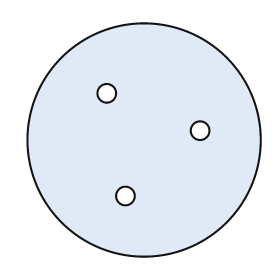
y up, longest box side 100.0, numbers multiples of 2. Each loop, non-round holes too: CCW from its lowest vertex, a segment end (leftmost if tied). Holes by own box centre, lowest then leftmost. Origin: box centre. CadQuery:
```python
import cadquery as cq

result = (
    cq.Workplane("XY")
    .moveTo(0.0, 0.0)
    .circle(50.0)
    .moveTo(-8.0, -24.0)
    .circle(4.0)
    .moveTo(24.0, 4.0)
    .circle(4.0)
    .moveTo(-16.0, 20.0)
    .circle(4.0)
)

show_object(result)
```